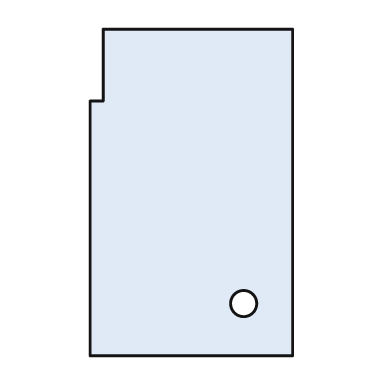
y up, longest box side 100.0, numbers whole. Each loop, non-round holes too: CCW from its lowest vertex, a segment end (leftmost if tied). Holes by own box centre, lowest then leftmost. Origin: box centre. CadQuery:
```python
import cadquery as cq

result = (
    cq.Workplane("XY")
    .moveTo(-31.0, -50.0)
    .lineTo(31.0, -50.0)
    .lineTo(31.0, 50.0)
    .lineTo(-27.0, 50.0)
    .lineTo(-27.0, 28.0)
    .lineTo(-31.0, 28.0)
    .close()
    .moveTo(16.0, -34.0)
    .circle(4.0)
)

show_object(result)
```